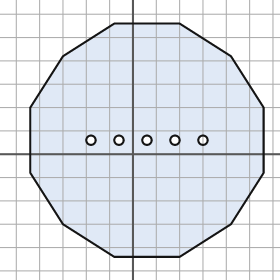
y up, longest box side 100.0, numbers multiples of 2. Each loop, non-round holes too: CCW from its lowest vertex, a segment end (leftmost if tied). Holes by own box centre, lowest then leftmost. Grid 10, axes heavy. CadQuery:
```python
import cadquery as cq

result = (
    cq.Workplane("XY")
    .moveTo(-8.0, -44.0)
    .lineTo(20.0, -44.0)
    .lineTo(42.0, -30.0)
    .lineTo(56.0, -8.0)
    .lineTo(56.0, 20.0)
    .lineTo(42.0, 42.0)
    .lineTo(20.0, 56.0)
    .lineTo(-8.0, 56.0)
    .lineTo(-30.0, 42.0)
    .lineTo(-44.0, 20.0)
    .lineTo(-44.0, -8.0)
    .lineTo(-30.0, -30.0)
    .close()
    .moveTo(-18.0, 6.0)
    .circle(2.0)
    .moveTo(-6.0, 6.0)
    .circle(2.0)
    .moveTo(6.0, 6.0)
    .circle(2.0)
    .moveTo(18.0, 6.0)
    .circle(2.0)
    .moveTo(30.0, 6.0)
    .circle(2.0)
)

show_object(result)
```